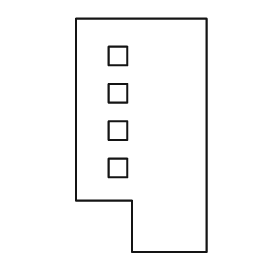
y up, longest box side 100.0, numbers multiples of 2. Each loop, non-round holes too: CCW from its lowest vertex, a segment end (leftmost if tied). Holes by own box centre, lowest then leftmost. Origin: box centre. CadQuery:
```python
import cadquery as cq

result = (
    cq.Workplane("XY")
    .moveTo(-4.0, -50.0)
    .lineTo(28.0, -50.0)
    .lineTo(28.0, 50.0)
    .lineTo(-28.0, 50.0)
    .lineTo(-28.0, -28.0)
    .lineTo(-4.0, -28.0)
    .close()
    .moveTo(-14.0, -18.0)
    .lineTo(-6.0, -18.0)
    .lineTo(-6.0, -10.0)
    .lineTo(-14.0, -10.0)
    .close()
    .moveTo(-14.0, -2.0)
    .lineTo(-6.0, -2.0)
    .lineTo(-6.0, 6.0)
    .lineTo(-14.0, 6.0)
    .close()
    .moveTo(-14.0, 14.0)
    .lineTo(-6.0, 14.0)
    .lineTo(-6.0, 22.0)
    .lineTo(-14.0, 22.0)
    .close()
    .moveTo(-14.0, 30.0)
    .lineTo(-6.0, 30.0)
    .lineTo(-6.0, 38.0)
    .lineTo(-14.0, 38.0)
    .close()
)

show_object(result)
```